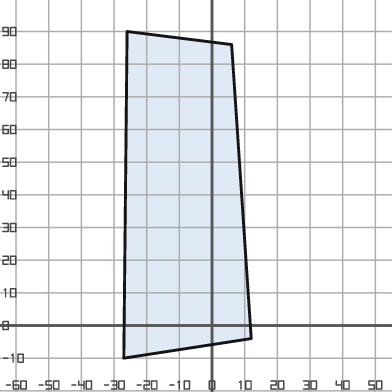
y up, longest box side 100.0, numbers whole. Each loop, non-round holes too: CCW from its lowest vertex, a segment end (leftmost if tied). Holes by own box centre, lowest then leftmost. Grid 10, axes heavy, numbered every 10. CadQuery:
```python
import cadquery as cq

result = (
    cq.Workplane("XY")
    .moveTo(-27.0, -10.0)
    .lineTo(12.0, -4.0)
    .lineTo(6.0, 86.0)
    .lineTo(-26.0, 90.0)
    .close()
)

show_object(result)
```